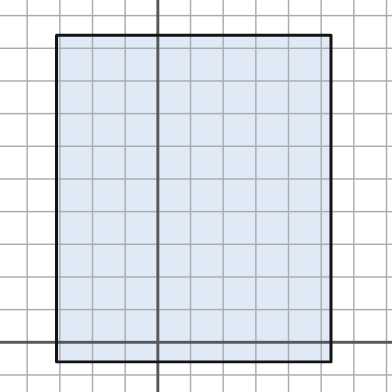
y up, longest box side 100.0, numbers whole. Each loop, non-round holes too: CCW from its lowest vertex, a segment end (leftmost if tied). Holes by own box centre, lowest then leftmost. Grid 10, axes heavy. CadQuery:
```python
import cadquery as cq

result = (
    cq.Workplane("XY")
    .moveTo(-31.0, -6.0)
    .lineTo(53.0, -6.0)
    .lineTo(53.0, 94.0)
    .lineTo(-31.0, 94.0)
    .close()
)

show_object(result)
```